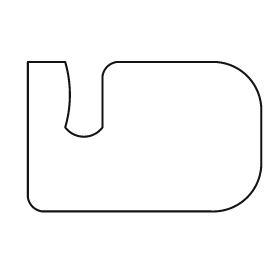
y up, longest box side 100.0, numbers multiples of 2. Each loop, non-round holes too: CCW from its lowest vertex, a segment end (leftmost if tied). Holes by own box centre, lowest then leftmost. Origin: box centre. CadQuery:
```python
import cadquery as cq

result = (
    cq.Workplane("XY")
    .moveTo(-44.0, -32.0)
    .lineTo(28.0, -32.0)
    .threePointArc((44.0, -26.0), (50.0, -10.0))
    .lineTo(50.0, 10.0)
    .threePointArc((44.0, 26.0), (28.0, 32.0))
    .lineTo(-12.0, 32.0)
    .threePointArc((-16.0, 30.0), (-18.0, 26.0))
    .lineTo(-18.0, 4.0)
    .threePointArc((-26.0, 0.0), (-34.0, 4.0))
    .threePointArc((-32.0, 18.0), (-34.0, 32.0))
    .lineTo(-50.0, 32.0)
    .lineTo(-50.0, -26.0)
    .threePointArc((-48.0, -30.0), (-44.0, -32.0))
    .close()
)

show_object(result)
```